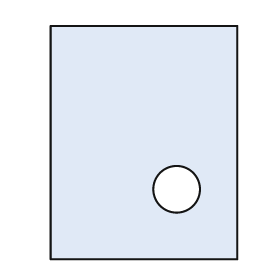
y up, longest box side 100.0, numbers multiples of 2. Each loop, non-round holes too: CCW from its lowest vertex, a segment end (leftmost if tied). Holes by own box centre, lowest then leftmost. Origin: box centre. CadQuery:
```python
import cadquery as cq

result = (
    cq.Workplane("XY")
    .moveTo(-40.0, -50.0)
    .lineTo(40.0, -50.0)
    .lineTo(40.0, 50.0)
    .lineTo(-40.0, 50.0)
    .close()
    .moveTo(14.0, -20.0)
    .circle(10.0)
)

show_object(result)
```